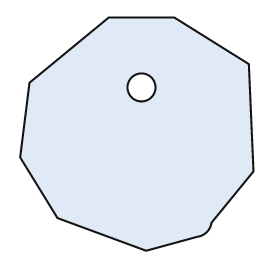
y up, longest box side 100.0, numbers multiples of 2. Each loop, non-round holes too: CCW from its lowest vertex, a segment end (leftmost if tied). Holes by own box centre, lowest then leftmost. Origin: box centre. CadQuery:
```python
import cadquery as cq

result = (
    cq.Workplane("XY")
    .moveTo(4.0, -50.0)
    .lineTo(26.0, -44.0)
    .threePointArc((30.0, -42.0), (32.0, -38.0))
    .lineTo(50.0, -16.0)
    .lineTo(48.0, 30.0)
    .lineTo(16.0, 50.0)
    .lineTo(-12.0, 50.0)
    .lineTo(-46.0, 22.0)
    .lineTo(-50.0, -10.0)
    .lineTo(-34.0, -36.0)
    .close()
    .moveTo(2.0, 20.0)
    .circle(6.0)
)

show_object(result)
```